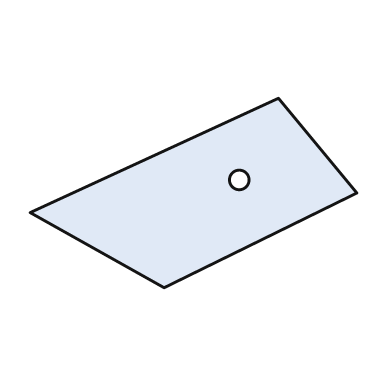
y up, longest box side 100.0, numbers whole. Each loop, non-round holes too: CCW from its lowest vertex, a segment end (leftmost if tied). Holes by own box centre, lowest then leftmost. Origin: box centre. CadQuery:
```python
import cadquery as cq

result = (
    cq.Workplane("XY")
    .moveTo(-9.0, -29.0)
    .lineTo(50.0, 0.0)
    .lineTo(26.0, 29.0)
    .lineTo(-50.0, -6.0)
    .close()
    .moveTo(14.0, 4.0)
    .circle(3.0)
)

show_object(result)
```